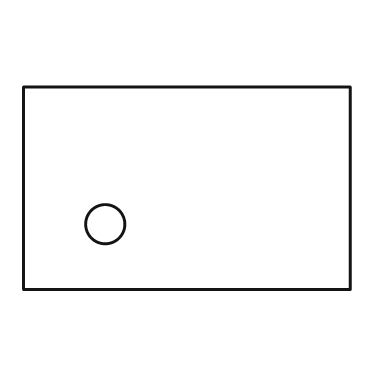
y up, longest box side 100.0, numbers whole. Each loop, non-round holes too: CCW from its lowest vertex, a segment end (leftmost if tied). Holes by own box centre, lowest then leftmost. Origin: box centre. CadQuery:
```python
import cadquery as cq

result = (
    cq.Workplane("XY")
    .moveTo(-50.0, -31.0)
    .lineTo(50.0, -31.0)
    .lineTo(50.0, 31.0)
    .lineTo(-50.0, 31.0)
    .close()
    .moveTo(-25.0, -11.0)
    .circle(6.0)
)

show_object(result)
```